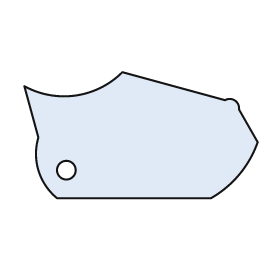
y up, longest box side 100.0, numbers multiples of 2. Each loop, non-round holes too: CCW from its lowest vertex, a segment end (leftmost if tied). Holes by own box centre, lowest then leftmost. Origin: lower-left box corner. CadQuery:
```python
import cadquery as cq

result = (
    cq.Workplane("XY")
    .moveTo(14.0, 0.0)
    .lineTo(80.0, 0.0)
    .threePointArc((92.0, 10.0), (100.0, 24.0))
    .lineTo(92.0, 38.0)
    .threePointArc((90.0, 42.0), (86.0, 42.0))
    .lineTo(42.0, 54.0)
    .threePointArc((22.0, 44.0), (0.0, 48.0))
    .lineTo(6.0, 26.0)
    .threePointArc((6.0, 12.0), (14.0, 0.0))
    .close()
    .moveTo(18.0, 12.0)
    .circle(4.0)
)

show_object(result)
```